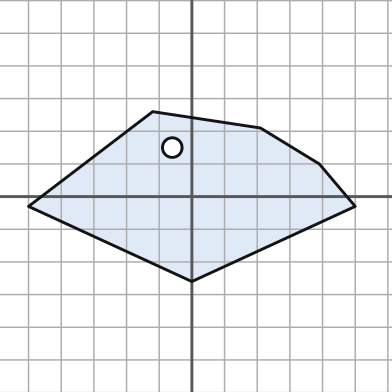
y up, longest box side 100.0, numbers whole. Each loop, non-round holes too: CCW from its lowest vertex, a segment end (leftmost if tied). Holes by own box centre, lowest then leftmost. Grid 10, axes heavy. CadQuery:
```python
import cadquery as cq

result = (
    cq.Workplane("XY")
    .moveTo(0.0, -26.0)
    .lineTo(50.0, -3.0)
    .lineTo(39.0, 10.0)
    .lineTo(21.0, 21.0)
    .lineTo(-12.0, 26.0)
    .lineTo(-50.0, -3.0)
    .close()
    .moveTo(-6.0, 15.0)
    .circle(3.0)
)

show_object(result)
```